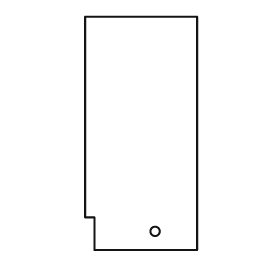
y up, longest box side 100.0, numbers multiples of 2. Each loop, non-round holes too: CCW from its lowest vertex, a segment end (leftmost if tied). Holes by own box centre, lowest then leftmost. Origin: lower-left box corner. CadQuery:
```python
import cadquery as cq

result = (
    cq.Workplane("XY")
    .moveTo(4.0, 0.0)
    .lineTo(48.0, 0.0)
    .lineTo(48.0, 100.0)
    .lineTo(0.0, 100.0)
    .lineTo(0.0, 14.0)
    .lineTo(4.0, 14.0)
    .close()
    .moveTo(30.0, 8.0)
    .circle(2.0)
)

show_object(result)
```